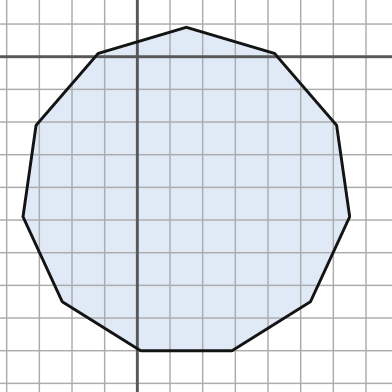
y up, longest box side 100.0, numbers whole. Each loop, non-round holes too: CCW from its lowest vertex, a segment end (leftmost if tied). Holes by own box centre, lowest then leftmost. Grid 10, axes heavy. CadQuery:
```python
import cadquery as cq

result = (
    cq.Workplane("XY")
    .moveTo(1.0, -90.0)
    .lineTo(29.0, -90.0)
    .lineTo(53.0, -75.0)
    .lineTo(65.0, -49.0)
    .lineTo(61.0, -21.0)
    .lineTo(42.0, 1.0)
    .lineTo(15.0, 9.0)
    .lineTo(-12.0, 1.0)
    .lineTo(-31.0, -21.0)
    .lineTo(-35.0, -49.0)
    .lineTo(-23.0, -75.0)
    .close()
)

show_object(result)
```